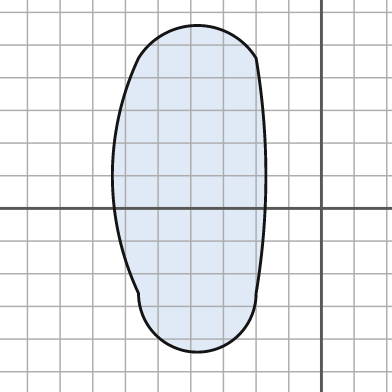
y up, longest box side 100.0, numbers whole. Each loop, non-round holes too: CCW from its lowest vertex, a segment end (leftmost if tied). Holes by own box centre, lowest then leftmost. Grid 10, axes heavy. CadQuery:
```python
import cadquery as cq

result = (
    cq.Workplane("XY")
    .moveTo(-56.0, -26.0)
    .threePointArc((-38.0, -44.0), (-20.0, -26.0))
    .threePointArc((-17.0, 10.0), (-20.0, 46.0))
    .threePointArc((-38.0, 56.0), (-56.0, 46.0))
    .threePointArc((-64.0, 10.0), (-56.0, -26.0))
    .close()
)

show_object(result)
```